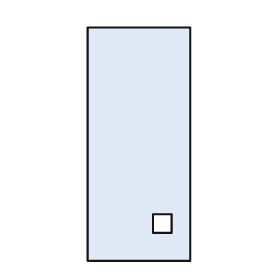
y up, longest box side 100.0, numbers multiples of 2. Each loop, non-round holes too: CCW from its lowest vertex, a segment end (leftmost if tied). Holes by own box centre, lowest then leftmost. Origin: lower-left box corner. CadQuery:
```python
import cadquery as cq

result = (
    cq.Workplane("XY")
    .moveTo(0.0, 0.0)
    .lineTo(44.0, 0.0)
    .lineTo(44.0, 100.0)
    .lineTo(0.0, 100.0)
    .close()
    .moveTo(28.0, 12.0)
    .lineTo(36.0, 12.0)
    .lineTo(36.0, 20.0)
    .lineTo(28.0, 20.0)
    .close()
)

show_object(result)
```